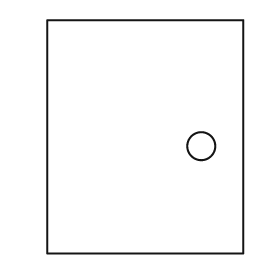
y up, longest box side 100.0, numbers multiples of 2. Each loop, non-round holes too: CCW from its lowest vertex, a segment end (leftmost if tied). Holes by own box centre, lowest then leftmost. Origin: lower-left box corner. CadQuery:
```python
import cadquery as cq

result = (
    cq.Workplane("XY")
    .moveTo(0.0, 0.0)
    .lineTo(84.0, 0.0)
    .lineTo(84.0, 100.0)
    .lineTo(0.0, 100.0)
    .close()
    .moveTo(66.0, 46.0)
    .circle(6.0)
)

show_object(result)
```